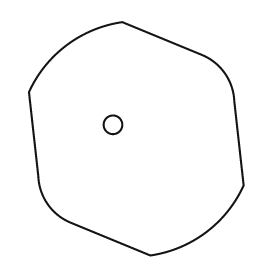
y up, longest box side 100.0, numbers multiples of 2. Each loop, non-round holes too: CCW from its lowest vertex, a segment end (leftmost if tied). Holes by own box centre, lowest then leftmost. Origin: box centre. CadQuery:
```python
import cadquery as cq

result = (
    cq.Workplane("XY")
    .moveTo(6.0, -50.0)
    .threePointArc((30.0, -40.0), (46.0, -20.0))
    .lineTo(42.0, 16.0)
    .threePointArc((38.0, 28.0), (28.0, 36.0))
    .lineTo(-6.0, 50.0)
    .threePointArc((-30.0, 40.0), (-46.0, 20.0))
    .lineTo(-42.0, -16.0)
    .threePointArc((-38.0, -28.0), (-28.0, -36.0))
    .close()
    .moveTo(-10.0, 6.0)
    .circle(4.0)
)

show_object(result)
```